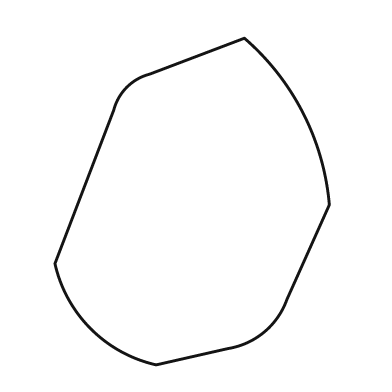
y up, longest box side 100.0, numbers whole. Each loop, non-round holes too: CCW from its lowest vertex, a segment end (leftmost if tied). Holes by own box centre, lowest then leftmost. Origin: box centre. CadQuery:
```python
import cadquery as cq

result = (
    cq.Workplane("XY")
    .moveTo(-11.0, -50.0)
    .lineTo(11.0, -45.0)
    .threePointArc((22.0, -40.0), (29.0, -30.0))
    .lineTo(42.0, -1.0)
    .threePointArc((34.0, 27.0), (16.0, 50.0))
    .lineTo(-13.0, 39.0)
    .threePointArc((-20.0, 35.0), (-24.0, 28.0))
    .lineTo(-42.0, -19.0)
    .threePointArc((-31.0, -39.0), (-11.0, -50.0))
    .close()
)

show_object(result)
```